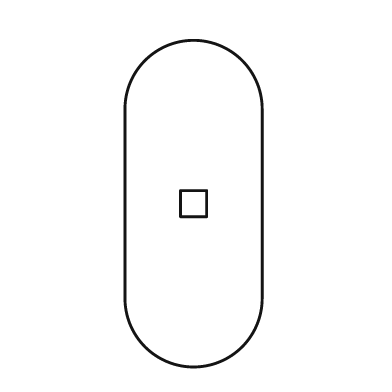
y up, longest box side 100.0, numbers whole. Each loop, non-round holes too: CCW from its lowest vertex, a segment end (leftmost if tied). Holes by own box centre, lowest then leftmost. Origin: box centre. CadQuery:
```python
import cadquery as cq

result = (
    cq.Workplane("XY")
    .moveTo(-21.0, -29.0)
    .threePointArc((0.0, -50.0), (21.0, -29.0))
    .lineTo(21.0, 29.0)
    .threePointArc((0.0, 50.0), (-21.0, 29.0))
    .close()
    .moveTo(-4.0, -4.0)
    .lineTo(4.0, -4.0)
    .lineTo(4.0, 4.0)
    .lineTo(-4.0, 4.0)
    .close()
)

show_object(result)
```